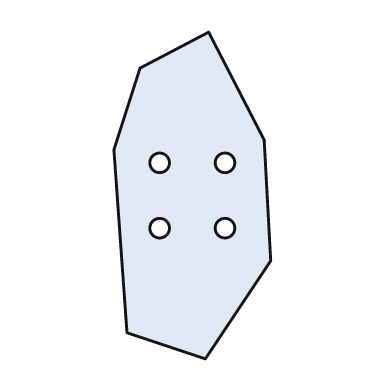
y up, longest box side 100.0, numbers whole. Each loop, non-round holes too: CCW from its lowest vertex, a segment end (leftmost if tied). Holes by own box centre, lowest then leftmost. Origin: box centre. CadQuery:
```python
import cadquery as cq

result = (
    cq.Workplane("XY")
    .moveTo(4.0, -50.0)
    .lineTo(24.0, -20.0)
    .lineTo(22.0, 17.0)
    .lineTo(5.0, 50.0)
    .lineTo(-16.0, 39.0)
    .lineTo(-24.0, 14.0)
    .lineTo(-20.0, -42.0)
    .close()
    .moveTo(-10.0, -10.0)
    .circle(3.0)
    .moveTo(10.0, -10.0)
    .circle(3.0)
    .moveTo(-10.0, 10.0)
    .circle(3.0)
    .moveTo(10.0, 10.0)
    .circle(3.0)
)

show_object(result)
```